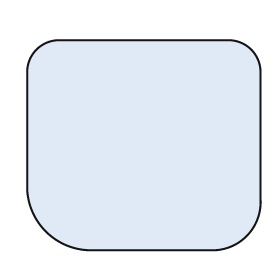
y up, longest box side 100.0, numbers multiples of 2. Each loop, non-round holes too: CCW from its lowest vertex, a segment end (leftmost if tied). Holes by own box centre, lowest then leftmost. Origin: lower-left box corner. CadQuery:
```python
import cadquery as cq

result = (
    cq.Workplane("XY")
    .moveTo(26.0, 0.0)
    .lineTo(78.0, 0.0)
    .threePointArc((94.0, 6.0), (100.0, 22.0))
    .lineTo(100.0, 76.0)
    .threePointArc((96.0, 86.0), (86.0, 90.0))
    .lineTo(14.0, 90.0)
    .threePointArc((4.0, 86.0), (0.0, 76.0))
    .lineTo(0.0, 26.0)
    .threePointArc((8.0, 8.0), (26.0, 0.0))
    .close()
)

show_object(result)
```